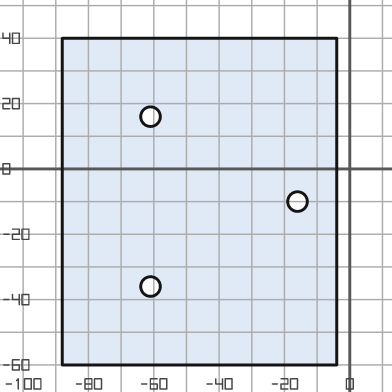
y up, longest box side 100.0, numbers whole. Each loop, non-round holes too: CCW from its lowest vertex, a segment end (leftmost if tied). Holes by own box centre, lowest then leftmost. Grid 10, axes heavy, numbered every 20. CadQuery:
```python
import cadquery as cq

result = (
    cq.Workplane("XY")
    .moveTo(-88.0, -60.0)
    .lineTo(-4.0, -60.0)
    .lineTo(-4.0, 40.0)
    .lineTo(-88.0, 40.0)
    .close()
    .moveTo(-61.0, -36.0)
    .circle(3.0)
    .moveTo(-16.0, -10.0)
    .circle(3.0)
    .moveTo(-61.0, 16.0)
    .circle(3.0)
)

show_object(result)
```